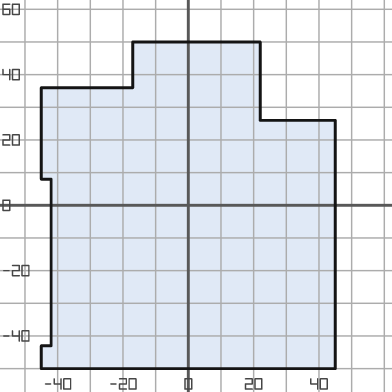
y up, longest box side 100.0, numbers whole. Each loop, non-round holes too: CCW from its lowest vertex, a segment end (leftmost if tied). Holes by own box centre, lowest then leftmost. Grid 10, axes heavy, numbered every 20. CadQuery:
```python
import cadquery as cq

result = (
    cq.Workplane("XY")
    .moveTo(-45.0, -50.0)
    .lineTo(45.0, -50.0)
    .lineTo(45.0, 26.0)
    .lineTo(22.0, 26.0)
    .lineTo(22.0, 50.0)
    .lineTo(-17.0, 50.0)
    .lineTo(-17.0, 36.0)
    .lineTo(-45.0, 36.0)
    .lineTo(-45.0, 8.0)
    .lineTo(-42.0, 8.0)
    .lineTo(-42.0, -43.0)
    .lineTo(-45.0, -43.0)
    .close()
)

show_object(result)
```